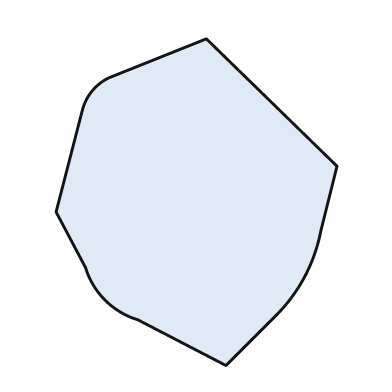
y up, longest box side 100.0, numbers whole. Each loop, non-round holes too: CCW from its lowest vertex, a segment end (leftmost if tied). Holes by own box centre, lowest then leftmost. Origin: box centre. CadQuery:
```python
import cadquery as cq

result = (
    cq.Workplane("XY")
    .moveTo(9.0, -50.0)
    .lineTo(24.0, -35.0)
    .threePointArc((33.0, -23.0), (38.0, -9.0))
    .lineTo(43.0, 11.0)
    .lineTo(3.0, 50.0)
    .lineTo(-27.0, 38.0)
    .threePointArc((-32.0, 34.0), (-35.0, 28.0))
    .lineTo(-43.0, -3.0)
    .lineTo(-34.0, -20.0)
    .threePointArc((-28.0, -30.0), (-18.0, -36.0))
    .close()
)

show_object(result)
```